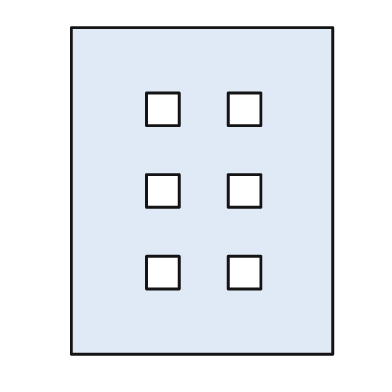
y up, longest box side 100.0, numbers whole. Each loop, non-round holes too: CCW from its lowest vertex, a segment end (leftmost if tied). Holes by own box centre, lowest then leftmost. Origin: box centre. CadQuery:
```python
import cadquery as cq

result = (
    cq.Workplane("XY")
    .moveTo(-40.0, -50.0)
    .lineTo(40.0, -50.0)
    .lineTo(40.0, 50.0)
    .lineTo(-40.0, 50.0)
    .close()
    .moveTo(-17.0, -30.0)
    .lineTo(-7.0, -30.0)
    .lineTo(-7.0, -20.0)
    .lineTo(-17.0, -20.0)
    .close()
    .moveTo(8.0, -30.0)
    .lineTo(18.0, -30.0)
    .lineTo(18.0, -20.0)
    .lineTo(8.0, -20.0)
    .close()
    .moveTo(-17.0, -5.0)
    .lineTo(-7.0, -5.0)
    .lineTo(-7.0, 5.0)
    .lineTo(-17.0, 5.0)
    .close()
    .moveTo(8.0, -5.0)
    .lineTo(18.0, -5.0)
    .lineTo(18.0, 5.0)
    .lineTo(8.0, 5.0)
    .close()
    .moveTo(-17.0, 20.0)
    .lineTo(-7.0, 20.0)
    .lineTo(-7.0, 30.0)
    .lineTo(-17.0, 30.0)
    .close()
    .moveTo(8.0, 20.0)
    .lineTo(18.0, 20.0)
    .lineTo(18.0, 30.0)
    .lineTo(8.0, 30.0)
    .close()
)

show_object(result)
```